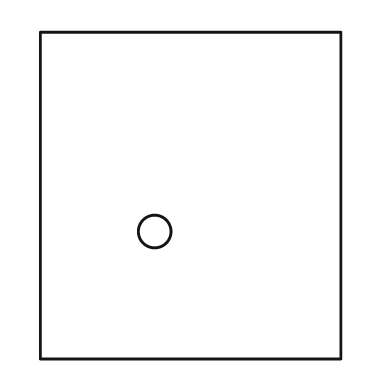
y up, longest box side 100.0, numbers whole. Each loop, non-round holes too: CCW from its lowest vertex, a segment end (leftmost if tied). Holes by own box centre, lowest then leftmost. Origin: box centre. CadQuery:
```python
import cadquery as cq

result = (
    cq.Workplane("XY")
    .moveTo(-46.0, -50.0)
    .lineTo(46.0, -50.0)
    .lineTo(46.0, 50.0)
    .lineTo(-46.0, 50.0)
    .close()
    .moveTo(-11.0, -11.0)
    .circle(5.0)
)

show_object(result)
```